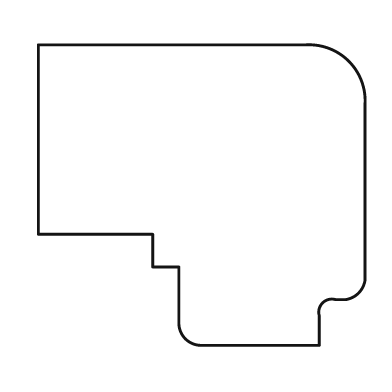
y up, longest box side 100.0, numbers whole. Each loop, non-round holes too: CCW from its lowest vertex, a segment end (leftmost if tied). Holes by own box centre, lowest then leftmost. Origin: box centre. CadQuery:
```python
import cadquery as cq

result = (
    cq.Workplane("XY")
    .moveTo(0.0, -46.0)
    .lineTo(36.0, -46.0)
    .lineTo(36.0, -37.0)
    .threePointArc((37.0, -33.0), (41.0, -32.0))
    .lineTo(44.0, -32.0)
    .threePointArc((48.0, -30.0), (50.0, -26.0))
    .lineTo(50.0, 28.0)
    .threePointArc((45.0, 41.0), (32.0, 46.0))
    .lineTo(-50.0, 46.0)
    .lineTo(-50.0, -12.0)
    .lineTo(-15.0, -12.0)
    .lineTo(-15.0, -22.0)
    .lineTo(-7.0, -22.0)
    .lineTo(-7.0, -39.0)
    .threePointArc((-5.0, -44.0), (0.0, -46.0))
    .close()
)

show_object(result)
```